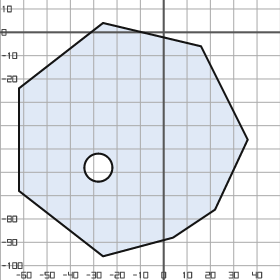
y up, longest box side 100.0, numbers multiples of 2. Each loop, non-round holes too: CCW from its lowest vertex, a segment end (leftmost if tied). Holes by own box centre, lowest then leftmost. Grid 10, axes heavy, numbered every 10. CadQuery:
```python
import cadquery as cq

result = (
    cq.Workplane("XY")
    .moveTo(-26.0, -96.0)
    .lineTo(4.0, -88.0)
    .lineTo(22.0, -76.0)
    .lineTo(36.0, -46.0)
    .lineTo(16.0, -6.0)
    .lineTo(-26.0, 4.0)
    .lineTo(-62.0, -24.0)
    .lineTo(-62.0, -68.0)
    .close()
    .moveTo(-28.0, -58.0)
    .circle(6.0)
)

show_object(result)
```